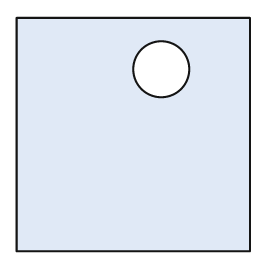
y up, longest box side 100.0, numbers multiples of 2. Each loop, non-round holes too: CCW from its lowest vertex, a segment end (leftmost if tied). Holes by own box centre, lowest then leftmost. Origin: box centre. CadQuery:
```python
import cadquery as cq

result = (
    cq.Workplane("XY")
    .moveTo(-50.0, -50.0)
    .lineTo(50.0, -50.0)
    .lineTo(50.0, 50.0)
    .lineTo(-50.0, 50.0)
    .close()
    .moveTo(12.0, 28.0)
    .circle(12.0)
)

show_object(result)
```